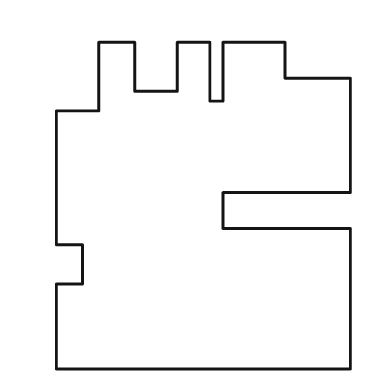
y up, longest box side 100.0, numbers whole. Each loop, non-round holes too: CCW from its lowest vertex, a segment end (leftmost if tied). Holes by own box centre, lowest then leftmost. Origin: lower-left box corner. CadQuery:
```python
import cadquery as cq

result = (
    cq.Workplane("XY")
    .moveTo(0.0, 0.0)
    .lineTo(90.0, 0.0)
    .lineTo(90.0, 43.0)
    .lineTo(51.0, 43.0)
    .lineTo(51.0, 54.0)
    .lineTo(90.0, 54.0)
    .lineTo(90.0, 89.0)
    .lineTo(70.0, 89.0)
    .lineTo(70.0, 100.0)
    .lineTo(51.0, 100.0)
    .lineTo(51.0, 82.0)
    .lineTo(47.0, 82.0)
    .lineTo(47.0, 100.0)
    .lineTo(37.0, 100.0)
    .lineTo(37.0, 85.0)
    .lineTo(24.0, 85.0)
    .lineTo(24.0, 100.0)
    .lineTo(13.0, 100.0)
    .lineTo(13.0, 79.0)
    .lineTo(0.0, 79.0)
    .lineTo(0.0, 38.0)
    .lineTo(8.0, 38.0)
    .lineTo(8.0, 26.0)
    .lineTo(0.0, 26.0)
    .close()
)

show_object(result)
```